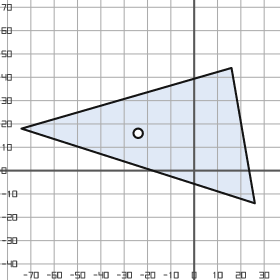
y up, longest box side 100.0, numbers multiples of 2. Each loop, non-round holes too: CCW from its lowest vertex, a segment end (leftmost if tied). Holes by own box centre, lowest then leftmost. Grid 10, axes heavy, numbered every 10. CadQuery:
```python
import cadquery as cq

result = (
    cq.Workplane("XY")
    .moveTo(26.0, -14.0)
    .lineTo(16.0, 44.0)
    .lineTo(-74.0, 18.0)
    .close()
    .moveTo(-24.0, 16.0)
    .circle(2.0)
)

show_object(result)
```